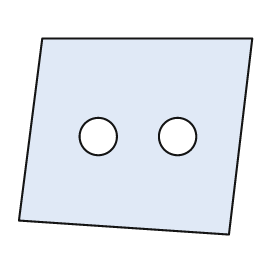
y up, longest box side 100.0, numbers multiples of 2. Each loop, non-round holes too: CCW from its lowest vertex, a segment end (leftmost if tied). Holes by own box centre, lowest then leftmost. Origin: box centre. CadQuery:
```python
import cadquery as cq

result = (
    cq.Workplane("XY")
    .moveTo(40.0, -42.0)
    .lineTo(50.0, 42.0)
    .lineTo(-40.0, 42.0)
    .lineTo(-50.0, -36.0)
    .close()
    .moveTo(-16.0, 0.0)
    .circle(8.0)
    .moveTo(18.0, 0.0)
    .circle(8.0)
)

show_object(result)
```